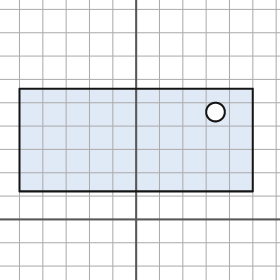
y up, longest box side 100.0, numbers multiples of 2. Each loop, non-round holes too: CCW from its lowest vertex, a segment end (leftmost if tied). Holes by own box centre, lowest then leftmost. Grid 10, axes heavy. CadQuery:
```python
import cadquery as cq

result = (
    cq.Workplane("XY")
    .moveTo(-50.0, 12.0)
    .lineTo(50.0, 12.0)
    .lineTo(50.0, 56.0)
    .lineTo(-50.0, 56.0)
    .close()
    .moveTo(34.0, 46.0)
    .circle(4.0)
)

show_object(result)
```